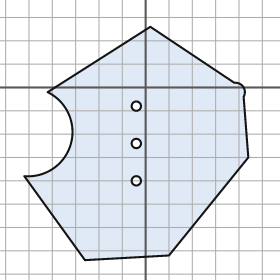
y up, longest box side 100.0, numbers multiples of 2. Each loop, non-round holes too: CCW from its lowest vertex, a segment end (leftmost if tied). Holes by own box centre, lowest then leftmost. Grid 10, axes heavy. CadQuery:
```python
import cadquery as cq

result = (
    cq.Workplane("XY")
    .moveTo(-26.0, -74.0)
    .lineTo(10.0, -72.0)
    .lineTo(44.0, -30.0)
    .lineTo(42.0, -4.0)
    .threePointArc((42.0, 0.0), (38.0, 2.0))
    .lineTo(2.0, 26.0)
    .lineTo(-42.0, -2.0)
    .threePointArc((-32.0, -24.0), (-52.0, -38.0))
    .close()
    .moveTo(-4.0, -40.0)
    .circle(2.0)
    .moveTo(-4.0, -24.0)
    .circle(2.0)
    .moveTo(-4.0, -8.0)
    .circle(2.0)
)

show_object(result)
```